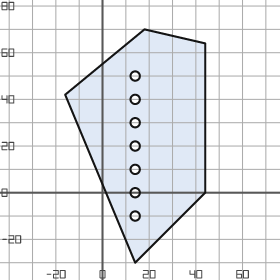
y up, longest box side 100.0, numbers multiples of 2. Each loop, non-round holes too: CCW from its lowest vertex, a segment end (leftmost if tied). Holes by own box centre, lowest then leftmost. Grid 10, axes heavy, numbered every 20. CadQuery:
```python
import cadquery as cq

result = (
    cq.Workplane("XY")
    .moveTo(14.0, -30.0)
    .lineTo(44.0, 0.0)
    .lineTo(44.0, 64.0)
    .lineTo(18.0, 70.0)
    .lineTo(-16.0, 42.0)
    .close()
    .moveTo(14.0, -10.0)
    .circle(2.0)
    .moveTo(14.0, 0.0)
    .circle(2.0)
    .moveTo(14.0, 10.0)
    .circle(2.0)
    .moveTo(14.0, 20.0)
    .circle(2.0)
    .moveTo(14.0, 30.0)
    .circle(2.0)
    .moveTo(14.0, 40.0)
    .circle(2.0)
    .moveTo(14.0, 50.0)
    .circle(2.0)
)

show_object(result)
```